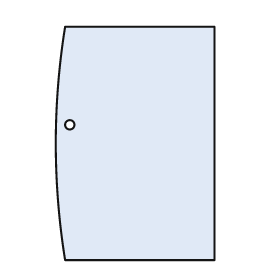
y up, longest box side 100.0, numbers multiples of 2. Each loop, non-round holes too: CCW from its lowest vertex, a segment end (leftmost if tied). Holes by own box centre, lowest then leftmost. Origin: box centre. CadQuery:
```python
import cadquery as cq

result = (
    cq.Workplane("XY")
    .moveTo(-30.0, -50.0)
    .lineTo(34.0, -50.0)
    .lineTo(34.0, 50.0)
    .lineTo(-30.0, 50.0)
    .threePointArc((-34.0, 0.0), (-30.0, -50.0))
    .close()
    .moveTo(-28.0, 8.0)
    .circle(2.0)
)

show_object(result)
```